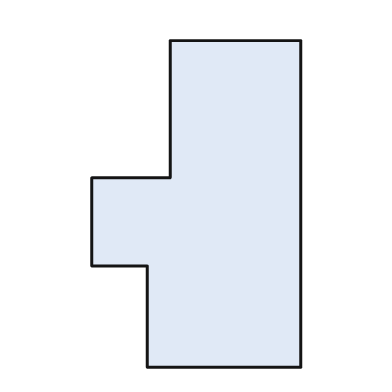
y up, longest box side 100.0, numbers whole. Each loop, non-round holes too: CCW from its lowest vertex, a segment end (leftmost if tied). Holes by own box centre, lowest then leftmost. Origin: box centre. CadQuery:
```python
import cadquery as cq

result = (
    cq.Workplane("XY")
    .moveTo(-15.0, -50.0)
    .lineTo(32.0, -50.0)
    .lineTo(32.0, 50.0)
    .lineTo(-8.0, 50.0)
    .lineTo(-8.0, 8.0)
    .lineTo(-32.0, 8.0)
    .lineTo(-32.0, -19.0)
    .lineTo(-15.0, -19.0)
    .close()
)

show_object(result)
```